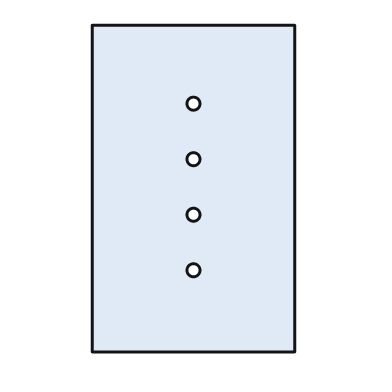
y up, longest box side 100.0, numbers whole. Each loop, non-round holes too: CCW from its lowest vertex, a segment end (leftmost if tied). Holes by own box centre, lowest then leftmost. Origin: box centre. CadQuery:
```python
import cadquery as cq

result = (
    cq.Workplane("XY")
    .moveTo(-31.0, -50.0)
    .lineTo(31.0, -50.0)
    .lineTo(31.0, 50.0)
    .lineTo(-31.0, 50.0)
    .close()
    .moveTo(0.0, -25.0)
    .circle(2.0)
    .moveTo(0.0, -8.0)
    .circle(2.0)
    .moveTo(0.0, 9.0)
    .circle(2.0)
    .moveTo(0.0, 26.0)
    .circle(2.0)
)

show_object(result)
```